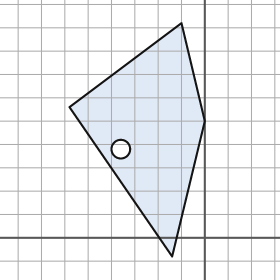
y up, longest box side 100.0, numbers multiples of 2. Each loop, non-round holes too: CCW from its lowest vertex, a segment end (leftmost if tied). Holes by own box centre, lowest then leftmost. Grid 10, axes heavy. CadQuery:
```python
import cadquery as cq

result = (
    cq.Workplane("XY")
    .moveTo(-14.0, -8.0)
    .lineTo(0.0, 50.0)
    .lineTo(-10.0, 92.0)
    .lineTo(-58.0, 56.0)
    .close()
    .moveTo(-36.0, 38.0)
    .circle(4.0)
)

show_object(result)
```